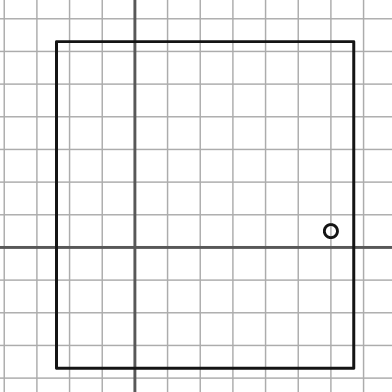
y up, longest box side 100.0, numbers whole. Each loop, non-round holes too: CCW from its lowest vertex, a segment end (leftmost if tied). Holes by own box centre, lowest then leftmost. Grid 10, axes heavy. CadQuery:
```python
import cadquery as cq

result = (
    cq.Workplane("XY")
    .moveTo(-24.0, -37.0)
    .lineTo(67.0, -37.0)
    .lineTo(67.0, 63.0)
    .lineTo(-24.0, 63.0)
    .close()
    .moveTo(60.0, 5.0)
    .circle(2.0)
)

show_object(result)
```